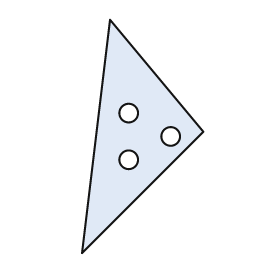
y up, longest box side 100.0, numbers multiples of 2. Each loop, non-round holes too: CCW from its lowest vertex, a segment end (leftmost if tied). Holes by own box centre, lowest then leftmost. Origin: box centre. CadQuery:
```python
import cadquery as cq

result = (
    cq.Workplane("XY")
    .moveTo(-26.0, -50.0)
    .lineTo(26.0, 2.0)
    .lineTo(-14.0, 50.0)
    .close()
    .moveTo(-6.0, -10.0)
    .circle(4.0)
    .moveTo(12.0, 0.0)
    .circle(4.0)
    .moveTo(-6.0, 10.0)
    .circle(4.0)
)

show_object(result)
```